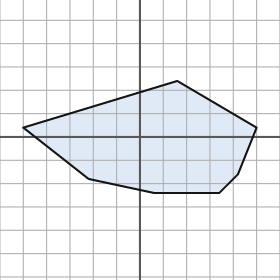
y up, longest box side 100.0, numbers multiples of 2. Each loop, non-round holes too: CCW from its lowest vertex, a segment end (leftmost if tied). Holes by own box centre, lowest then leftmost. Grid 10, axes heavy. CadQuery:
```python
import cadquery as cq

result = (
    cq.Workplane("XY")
    .moveTo(6.0, -24.0)
    .lineTo(34.0, -24.0)
    .lineTo(42.0, -16.0)
    .lineTo(50.0, 4.0)
    .lineTo(16.0, 24.0)
    .lineTo(-50.0, 4.0)
    .lineTo(-22.0, -18.0)
    .close()
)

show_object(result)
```